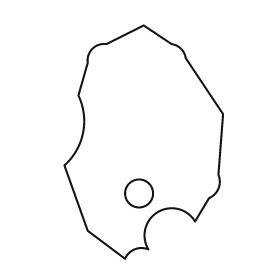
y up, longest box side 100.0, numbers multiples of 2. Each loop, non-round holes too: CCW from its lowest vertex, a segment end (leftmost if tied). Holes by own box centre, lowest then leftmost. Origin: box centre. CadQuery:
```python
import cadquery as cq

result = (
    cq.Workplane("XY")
    .moveTo(-8.0, -50.0)
    .threePointArc((-4.0, -46.0), (2.0, -46.0))
    .threePointArc((6.0, -30.0), (22.0, -34.0))
    .lineTo(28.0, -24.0)
    .threePointArc((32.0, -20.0), (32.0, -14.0))
    .lineTo(34.0, 12.0)
    .lineTo(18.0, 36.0)
    .threePointArc((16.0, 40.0), (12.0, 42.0))
    .lineTo(0.0, 50.0)
    .lineTo(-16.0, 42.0)
    .threePointArc((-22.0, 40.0), (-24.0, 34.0))
    .lineTo(-28.0, 20.0)
    .threePointArc((-26.0, 4.0), (-34.0, -10.0))
    .lineTo(-24.0, -38.0)
    .close()
    .moveTo(-2.0, -22.0)
    .circle(6.0)
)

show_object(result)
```